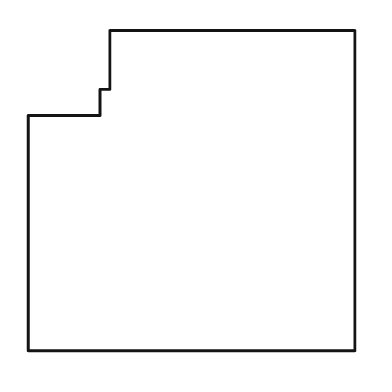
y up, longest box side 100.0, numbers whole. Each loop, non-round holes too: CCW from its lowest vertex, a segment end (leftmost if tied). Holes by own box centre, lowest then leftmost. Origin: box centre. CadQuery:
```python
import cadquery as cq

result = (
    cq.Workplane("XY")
    .moveTo(-50.0, -49.0)
    .lineTo(50.0, -49.0)
    .lineTo(50.0, 49.0)
    .lineTo(-25.0, 49.0)
    .lineTo(-25.0, 31.0)
    .lineTo(-28.0, 31.0)
    .lineTo(-28.0, 23.0)
    .lineTo(-50.0, 23.0)
    .close()
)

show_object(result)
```